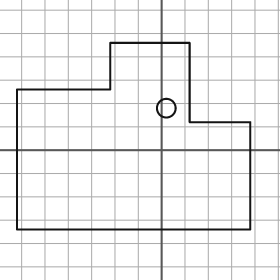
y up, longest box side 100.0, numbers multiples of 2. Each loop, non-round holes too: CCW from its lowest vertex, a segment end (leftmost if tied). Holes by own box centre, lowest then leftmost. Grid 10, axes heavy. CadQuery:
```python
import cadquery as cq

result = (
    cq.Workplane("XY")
    .moveTo(-62.0, -34.0)
    .lineTo(38.0, -34.0)
    .lineTo(38.0, 12.0)
    .lineTo(12.0, 12.0)
    .lineTo(12.0, 46.0)
    .lineTo(-22.0, 46.0)
    .lineTo(-22.0, 26.0)
    .lineTo(-62.0, 26.0)
    .close()
    .moveTo(2.0, 18.0)
    .circle(4.0)
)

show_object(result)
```